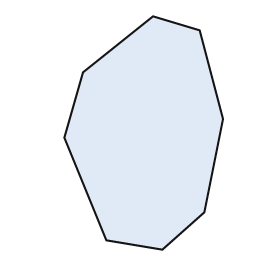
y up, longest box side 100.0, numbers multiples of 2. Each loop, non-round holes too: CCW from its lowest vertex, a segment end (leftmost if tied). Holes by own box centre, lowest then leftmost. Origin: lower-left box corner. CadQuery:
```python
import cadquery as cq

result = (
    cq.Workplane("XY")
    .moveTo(42.0, 0.0)
    .lineTo(60.0, 16.0)
    .lineTo(68.0, 56.0)
    .lineTo(58.0, 94.0)
    .lineTo(38.0, 100.0)
    .lineTo(8.0, 76.0)
    .lineTo(0.0, 48.0)
    .lineTo(18.0, 4.0)
    .close()
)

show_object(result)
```